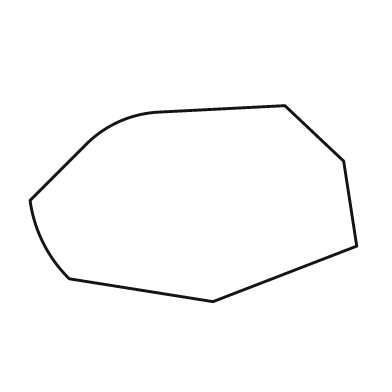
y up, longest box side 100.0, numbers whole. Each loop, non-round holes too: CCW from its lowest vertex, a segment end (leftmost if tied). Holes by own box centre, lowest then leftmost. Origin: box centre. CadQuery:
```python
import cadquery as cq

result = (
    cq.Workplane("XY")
    .moveTo(6.0, -30.0)
    .lineTo(50.0, -13.0)
    .lineTo(46.0, 13.0)
    .lineTo(28.0, 30.0)
    .lineTo(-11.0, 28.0)
    .threePointArc((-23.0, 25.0), (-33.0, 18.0))
    .lineTo(-50.0, 1.0)
    .threePointArc((-46.0, -12.0), (-38.0, -23.0))
    .close()
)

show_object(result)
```